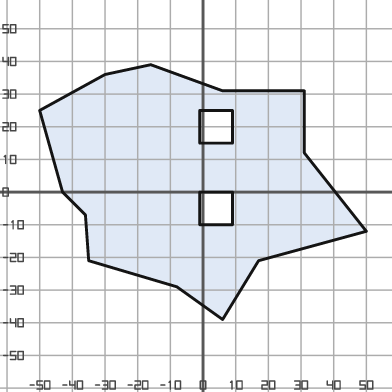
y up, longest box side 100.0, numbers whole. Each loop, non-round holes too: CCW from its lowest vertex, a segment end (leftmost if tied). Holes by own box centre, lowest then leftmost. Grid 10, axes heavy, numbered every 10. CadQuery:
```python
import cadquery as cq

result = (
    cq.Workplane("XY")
    .moveTo(6.0, -39.0)
    .lineTo(17.0, -21.0)
    .lineTo(50.0, -12.0)
    .lineTo(31.0, 12.0)
    .lineTo(31.0, 31.0)
    .lineTo(6.0, 31.0)
    .lineTo(-16.0, 39.0)
    .lineTo(-30.0, 36.0)
    .lineTo(-50.0, 25.0)
    .lineTo(-43.0, 0.0)
    .lineTo(-36.0, -7.0)
    .lineTo(-35.0, -21.0)
    .lineTo(-8.0, -29.0)
    .close()
    .moveTo(-1.0, -10.0)
    .lineTo(9.0, -10.0)
    .lineTo(9.0, 0.0)
    .lineTo(-1.0, 0.0)
    .close()
    .moveTo(-1.0, 15.0)
    .lineTo(9.0, 15.0)
    .lineTo(9.0, 25.0)
    .lineTo(-1.0, 25.0)
    .close()
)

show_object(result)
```